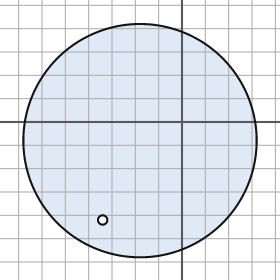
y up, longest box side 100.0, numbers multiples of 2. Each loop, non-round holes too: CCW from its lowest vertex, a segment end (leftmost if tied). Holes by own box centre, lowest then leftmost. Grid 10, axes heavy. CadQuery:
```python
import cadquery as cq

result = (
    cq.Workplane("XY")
    .moveTo(-18.0, -8.0)
    .circle(50.0)
    .moveTo(-34.0, -42.0)
    .circle(2.0)
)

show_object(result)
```